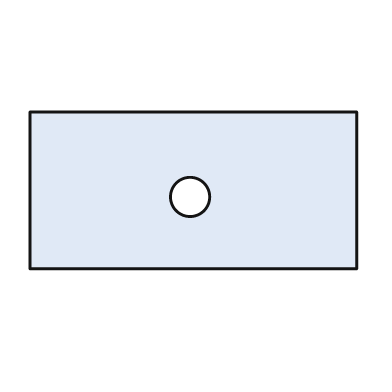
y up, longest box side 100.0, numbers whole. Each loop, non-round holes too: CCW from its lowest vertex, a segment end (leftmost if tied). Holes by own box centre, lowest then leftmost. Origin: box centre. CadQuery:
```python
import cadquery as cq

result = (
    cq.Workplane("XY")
    .moveTo(-50.0, -24.0)
    .lineTo(50.0, -24.0)
    .lineTo(50.0, 24.0)
    .lineTo(-50.0, 24.0)
    .close()
    .moveTo(-1.0, -2.0)
    .circle(6.0)
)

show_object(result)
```